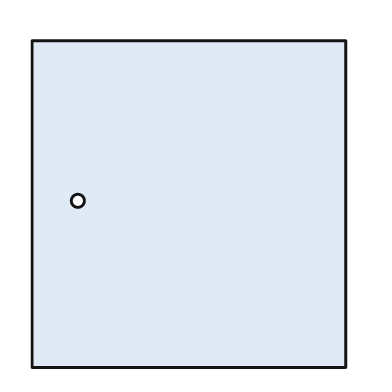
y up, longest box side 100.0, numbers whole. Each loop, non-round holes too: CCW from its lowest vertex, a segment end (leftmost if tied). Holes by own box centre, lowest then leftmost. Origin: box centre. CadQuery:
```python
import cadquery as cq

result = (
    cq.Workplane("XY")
    .moveTo(-48.0, -50.0)
    .lineTo(48.0, -50.0)
    .lineTo(48.0, 50.0)
    .lineTo(-48.0, 50.0)
    .close()
    .moveTo(-34.0, 1.0)
    .circle(2.0)
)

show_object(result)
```